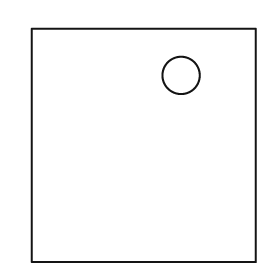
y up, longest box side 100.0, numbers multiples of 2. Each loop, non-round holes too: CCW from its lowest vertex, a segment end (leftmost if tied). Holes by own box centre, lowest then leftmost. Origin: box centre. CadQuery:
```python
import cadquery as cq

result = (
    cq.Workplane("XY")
    .moveTo(-48.0, -50.0)
    .lineTo(48.0, -50.0)
    .lineTo(48.0, 50.0)
    .lineTo(-48.0, 50.0)
    .close()
    .moveTo(16.0, 30.0)
    .circle(8.0)
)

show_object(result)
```